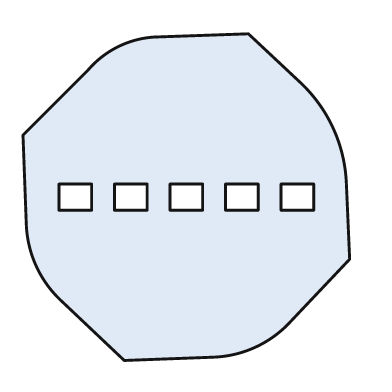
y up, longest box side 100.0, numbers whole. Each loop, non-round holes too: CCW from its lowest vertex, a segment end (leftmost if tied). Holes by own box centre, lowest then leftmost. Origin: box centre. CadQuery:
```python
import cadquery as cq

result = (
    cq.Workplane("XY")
    .moveTo(-19.0, -50.0)
    .lineTo(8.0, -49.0)
    .threePointArc((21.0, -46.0), (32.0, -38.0))
    .lineTo(50.0, -19.0)
    .lineTo(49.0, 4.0)
    .threePointArc((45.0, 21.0), (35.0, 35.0))
    .lineTo(19.0, 50.0)
    .lineTo(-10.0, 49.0)
    .threePointArc((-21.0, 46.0), (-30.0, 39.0))
    .lineTo(-50.0, 19.0)
    .lineTo(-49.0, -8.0)
    .threePointArc((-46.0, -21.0), (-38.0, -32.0))
    .close()
    .moveTo(-39.0, -4.0)
    .lineTo(-29.0, -4.0)
    .lineTo(-29.0, 4.0)
    .lineTo(-39.0, 4.0)
    .close()
    .moveTo(-22.0, -4.0)
    .lineTo(-12.0, -4.0)
    .lineTo(-12.0, 4.0)
    .lineTo(-22.0, 4.0)
    .close()
    .moveTo(-5.0, -4.0)
    .lineTo(5.0, -4.0)
    .lineTo(5.0, 4.0)
    .lineTo(-5.0, 4.0)
    .close()
    .moveTo(12.0, -4.0)
    .lineTo(22.0, -4.0)
    .lineTo(22.0, 4.0)
    .lineTo(12.0, 4.0)
    .close()
    .moveTo(29.0, -4.0)
    .lineTo(39.0, -4.0)
    .lineTo(39.0, 4.0)
    .lineTo(29.0, 4.0)
    .close()
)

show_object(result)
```